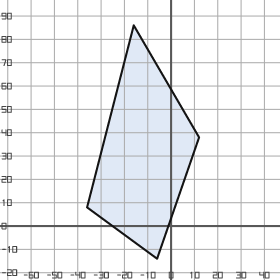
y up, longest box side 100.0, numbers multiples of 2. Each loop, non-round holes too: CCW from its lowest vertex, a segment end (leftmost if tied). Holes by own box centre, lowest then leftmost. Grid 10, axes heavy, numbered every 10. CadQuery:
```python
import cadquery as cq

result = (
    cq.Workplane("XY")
    .moveTo(-6.0, -14.0)
    .lineTo(12.0, 38.0)
    .lineTo(-16.0, 86.0)
    .lineTo(-36.0, 8.0)
    .close()
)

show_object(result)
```